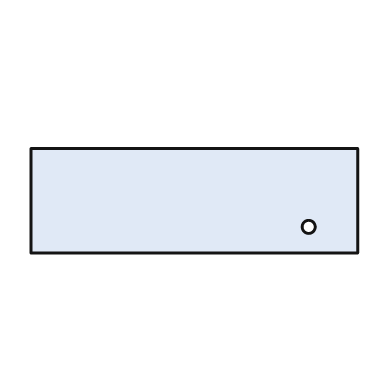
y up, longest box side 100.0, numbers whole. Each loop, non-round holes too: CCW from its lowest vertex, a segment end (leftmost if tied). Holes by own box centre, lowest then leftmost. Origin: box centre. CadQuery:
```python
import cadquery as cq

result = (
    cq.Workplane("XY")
    .moveTo(-50.0, -16.0)
    .lineTo(50.0, -16.0)
    .lineTo(50.0, 16.0)
    .lineTo(-50.0, 16.0)
    .close()
    .moveTo(35.0, -8.0)
    .circle(2.0)
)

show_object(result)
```